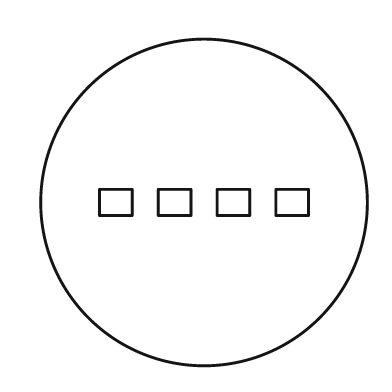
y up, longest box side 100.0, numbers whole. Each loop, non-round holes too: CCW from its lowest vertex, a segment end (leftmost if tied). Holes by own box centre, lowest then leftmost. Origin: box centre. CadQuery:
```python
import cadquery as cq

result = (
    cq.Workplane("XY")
    .moveTo(0.0, 0.0)
    .circle(50.0)
    .moveTo(-32.0, -4.0)
    .lineTo(-22.0, -4.0)
    .lineTo(-22.0, 4.0)
    .lineTo(-32.0, 4.0)
    .close()
    .moveTo(-14.0, -4.0)
    .lineTo(-4.0, -4.0)
    .lineTo(-4.0, 4.0)
    .lineTo(-14.0, 4.0)
    .close()
    .moveTo(4.0, -4.0)
    .lineTo(14.0, -4.0)
    .lineTo(14.0, 4.0)
    .lineTo(4.0, 4.0)
    .close()
    .moveTo(22.0, -4.0)
    .lineTo(32.0, -4.0)
    .lineTo(32.0, 4.0)
    .lineTo(22.0, 4.0)
    .close()
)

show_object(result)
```